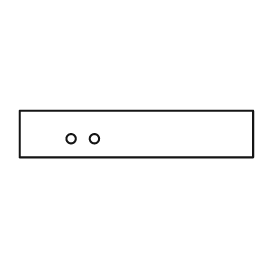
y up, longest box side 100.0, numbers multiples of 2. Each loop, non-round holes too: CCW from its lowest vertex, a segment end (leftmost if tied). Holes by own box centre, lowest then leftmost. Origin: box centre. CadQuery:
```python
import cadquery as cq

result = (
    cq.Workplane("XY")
    .moveTo(-50.0, -10.0)
    .lineTo(50.0, -10.0)
    .lineTo(50.0, 10.0)
    .lineTo(-50.0, 10.0)
    .close()
    .moveTo(-28.0, -2.0)
    .circle(2.0)
    .moveTo(-18.0, -2.0)
    .circle(2.0)
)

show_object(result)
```